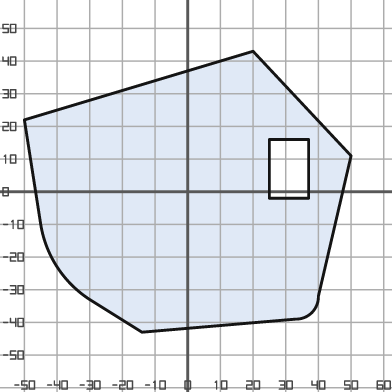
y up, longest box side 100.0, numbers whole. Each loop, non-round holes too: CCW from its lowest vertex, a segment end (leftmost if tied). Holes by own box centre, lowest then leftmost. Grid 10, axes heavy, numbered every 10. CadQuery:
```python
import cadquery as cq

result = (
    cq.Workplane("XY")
    .moveTo(-14.0, -43.0)
    .lineTo(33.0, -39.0)
    .threePointArc((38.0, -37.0), (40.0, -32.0))
    .lineTo(50.0, 11.0)
    .lineTo(20.0, 43.0)
    .lineTo(-50.0, 22.0)
    .lineTo(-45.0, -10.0)
    .threePointArc((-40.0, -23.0), (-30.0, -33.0))
    .close()
    .moveTo(25.0, -2.0)
    .lineTo(37.0, -2.0)
    .lineTo(37.0, 16.0)
    .lineTo(25.0, 16.0)
    .close()
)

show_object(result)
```